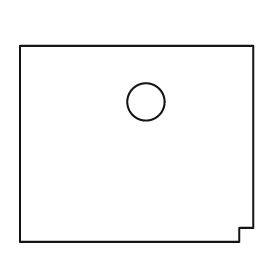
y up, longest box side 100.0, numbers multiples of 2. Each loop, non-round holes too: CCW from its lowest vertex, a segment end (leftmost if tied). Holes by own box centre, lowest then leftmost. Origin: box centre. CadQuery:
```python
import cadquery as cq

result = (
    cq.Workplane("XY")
    .moveTo(-50.0, -42.0)
    .lineTo(44.0, -42.0)
    .lineTo(44.0, -36.0)
    .lineTo(50.0, -36.0)
    .lineTo(50.0, 42.0)
    .lineTo(-50.0, 42.0)
    .close()
    .moveTo(4.0, 18.0)
    .circle(8.0)
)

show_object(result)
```